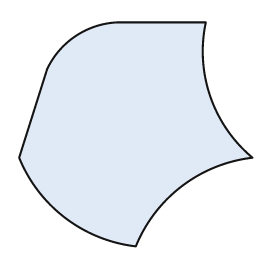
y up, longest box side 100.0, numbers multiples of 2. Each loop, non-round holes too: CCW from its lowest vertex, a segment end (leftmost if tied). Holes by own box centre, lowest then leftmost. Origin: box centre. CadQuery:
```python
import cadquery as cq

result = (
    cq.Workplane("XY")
    .moveTo(0.0, -48.0)
    .threePointArc((20.0, -22.0), (50.0, -10.0))
    .threePointArc((32.0, 16.0), (30.0, 48.0))
    .lineTo(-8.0, 48.0)
    .threePointArc((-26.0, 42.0), (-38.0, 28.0))
    .lineTo(-50.0, -10.0)
    .threePointArc((-30.0, -36.0), (0.0, -48.0))
    .close()
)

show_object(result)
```